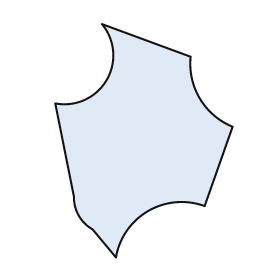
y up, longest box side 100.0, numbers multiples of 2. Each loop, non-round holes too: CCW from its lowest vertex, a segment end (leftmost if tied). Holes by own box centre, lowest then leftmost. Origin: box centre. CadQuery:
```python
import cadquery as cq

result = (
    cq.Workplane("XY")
    .moveTo(-12.0, -50.0)
    .threePointArc((2.0, -30.0), (26.0, -28.0))
    .lineTo(38.0, 6.0)
    .threePointArc((24.0, 18.0), (20.0, 36.0))
    .lineTo(-18.0, 50.0)
    .threePointArc((-16.0, 26.0), (-38.0, 16.0))
    .lineTo(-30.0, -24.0)
    .threePointArc((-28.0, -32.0), (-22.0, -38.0))
    .close()
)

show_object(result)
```